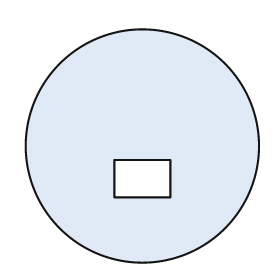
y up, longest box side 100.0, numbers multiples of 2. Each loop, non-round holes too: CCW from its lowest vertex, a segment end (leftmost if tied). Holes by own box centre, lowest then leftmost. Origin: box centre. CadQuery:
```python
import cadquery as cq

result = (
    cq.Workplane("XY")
    .moveTo(0.0, 0.0)
    .circle(50.0)
    .moveTo(-12.0, -22.0)
    .lineTo(12.0, -22.0)
    .lineTo(12.0, -6.0)
    .lineTo(-12.0, -6.0)
    .close()
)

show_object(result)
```